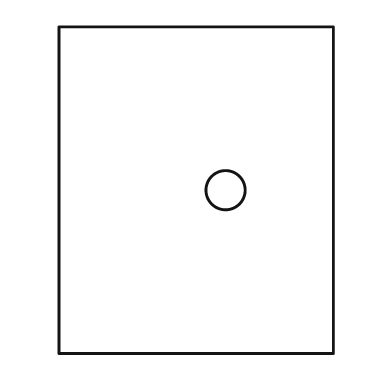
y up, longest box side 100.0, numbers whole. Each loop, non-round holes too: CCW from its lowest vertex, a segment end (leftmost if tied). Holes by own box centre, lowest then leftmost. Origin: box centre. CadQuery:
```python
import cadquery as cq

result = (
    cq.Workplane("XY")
    .moveTo(-42.0, -50.0)
    .lineTo(42.0, -50.0)
    .lineTo(42.0, 50.0)
    .lineTo(-42.0, 50.0)
    .close()
    .moveTo(9.0, 0.0)
    .circle(6.0)
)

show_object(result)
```